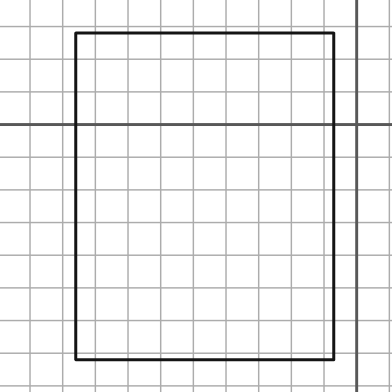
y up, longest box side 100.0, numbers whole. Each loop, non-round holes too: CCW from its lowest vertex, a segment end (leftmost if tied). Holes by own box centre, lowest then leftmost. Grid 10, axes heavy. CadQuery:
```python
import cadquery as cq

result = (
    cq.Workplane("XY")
    .moveTo(-86.0, -72.0)
    .lineTo(-7.0, -72.0)
    .lineTo(-7.0, 28.0)
    .lineTo(-86.0, 28.0)
    .close()
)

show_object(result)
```